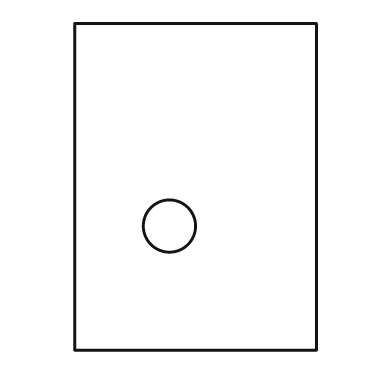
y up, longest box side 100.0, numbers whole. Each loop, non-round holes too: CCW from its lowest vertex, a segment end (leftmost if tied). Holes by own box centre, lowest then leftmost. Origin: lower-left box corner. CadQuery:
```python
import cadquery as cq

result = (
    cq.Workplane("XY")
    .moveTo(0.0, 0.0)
    .lineTo(74.0, 0.0)
    .lineTo(74.0, 100.0)
    .lineTo(0.0, 100.0)
    .close()
    .moveTo(29.0, 38.0)
    .circle(8.0)
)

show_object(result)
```